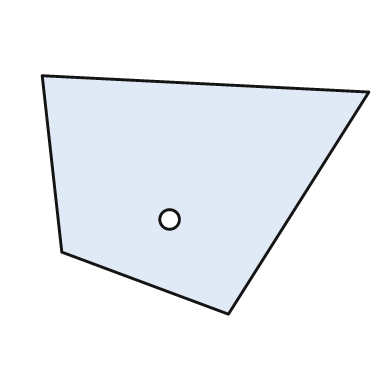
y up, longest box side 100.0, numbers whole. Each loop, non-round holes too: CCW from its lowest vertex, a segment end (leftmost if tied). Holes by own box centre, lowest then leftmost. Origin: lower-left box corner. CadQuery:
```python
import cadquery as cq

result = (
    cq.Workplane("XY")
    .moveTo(57.0, 0.0)
    .lineTo(100.0, 68.0)
    .lineTo(0.0, 73.0)
    .lineTo(6.0, 19.0)
    .close()
    .moveTo(39.0, 29.0)
    .circle(3.0)
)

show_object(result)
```